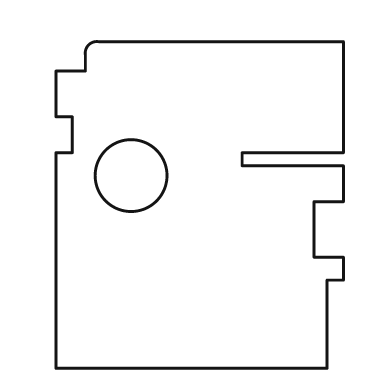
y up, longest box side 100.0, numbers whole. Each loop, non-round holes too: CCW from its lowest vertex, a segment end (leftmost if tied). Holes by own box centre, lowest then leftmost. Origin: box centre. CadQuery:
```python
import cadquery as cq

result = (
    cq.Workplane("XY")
    .moveTo(-44.0, -50.0)
    .lineTo(39.0, -50.0)
    .lineTo(39.0, -23.0)
    .lineTo(44.0, -23.0)
    .lineTo(44.0, -16.0)
    .lineTo(35.0, -16.0)
    .lineTo(35.0, 1.0)
    .lineTo(44.0, 1.0)
    .lineTo(44.0, 12.0)
    .lineTo(13.0, 12.0)
    .lineTo(13.0, 16.0)
    .lineTo(44.0, 16.0)
    .lineTo(44.0, 50.0)
    .lineTo(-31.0, 50.0)
    .threePointArc((-34.0, 49.0), (-35.0, 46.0))
    .lineTo(-35.0, 41.0)
    .lineTo(-44.0, 41.0)
    .lineTo(-44.0, 27.0)
    .lineTo(-39.0, 27.0)
    .lineTo(-39.0, 16.0)
    .lineTo(-44.0, 16.0)
    .close()
    .moveTo(-21.0, 9.0)
    .circle(11.0)
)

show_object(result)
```